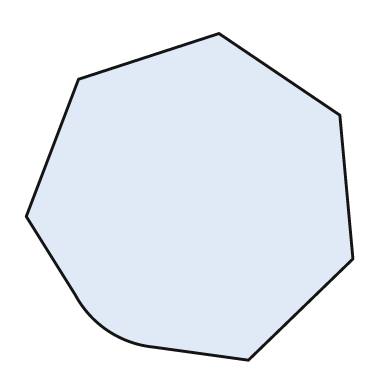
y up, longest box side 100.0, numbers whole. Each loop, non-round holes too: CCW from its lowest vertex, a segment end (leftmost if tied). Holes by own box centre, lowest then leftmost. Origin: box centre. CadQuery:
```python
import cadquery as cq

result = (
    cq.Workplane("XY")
    .moveTo(18.0, -50.0)
    .lineTo(50.0, -19.0)
    .lineTo(46.0, 25.0)
    .lineTo(9.0, 50.0)
    .lineTo(-34.0, 36.0)
    .lineTo(-50.0, -6.0)
    .lineTo(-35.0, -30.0)
    .threePointArc((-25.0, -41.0), (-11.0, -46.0))
    .close()
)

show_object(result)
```